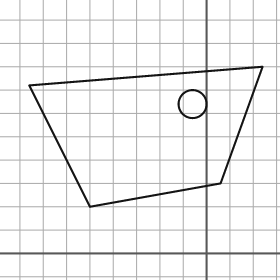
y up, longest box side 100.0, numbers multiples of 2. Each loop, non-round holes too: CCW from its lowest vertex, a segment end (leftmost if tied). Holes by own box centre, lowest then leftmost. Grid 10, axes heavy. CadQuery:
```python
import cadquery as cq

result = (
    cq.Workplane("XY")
    .moveTo(-50.0, 20.0)
    .lineTo(6.0, 30.0)
    .lineTo(24.0, 80.0)
    .lineTo(-76.0, 72.0)
    .close()
    .moveTo(-6.0, 64.0)
    .circle(6.0)
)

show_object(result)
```